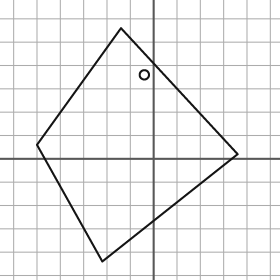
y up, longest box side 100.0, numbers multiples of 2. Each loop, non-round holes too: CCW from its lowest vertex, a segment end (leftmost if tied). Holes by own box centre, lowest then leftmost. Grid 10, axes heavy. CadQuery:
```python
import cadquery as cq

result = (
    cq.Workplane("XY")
    .moveTo(-22.0, -44.0)
    .lineTo(36.0, 2.0)
    .lineTo(-14.0, 56.0)
    .lineTo(-50.0, 6.0)
    .close()
    .moveTo(-4.0, 36.0)
    .circle(2.0)
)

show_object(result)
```